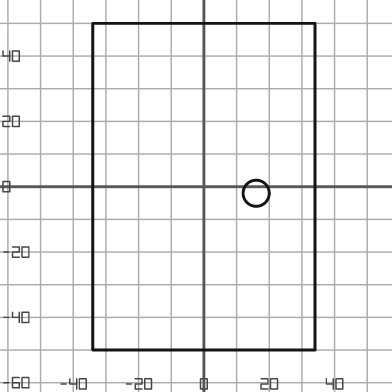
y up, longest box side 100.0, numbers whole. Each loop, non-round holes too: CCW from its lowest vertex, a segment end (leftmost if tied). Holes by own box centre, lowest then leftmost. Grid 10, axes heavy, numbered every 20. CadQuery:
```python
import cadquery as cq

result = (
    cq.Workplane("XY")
    .moveTo(-34.0, -50.0)
    .lineTo(34.0, -50.0)
    .lineTo(34.0, 50.0)
    .lineTo(-34.0, 50.0)
    .close()
    .moveTo(16.0, -2.0)
    .circle(4.0)
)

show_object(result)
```